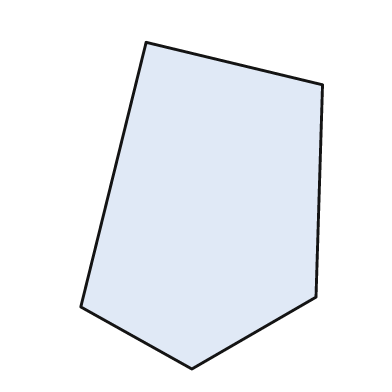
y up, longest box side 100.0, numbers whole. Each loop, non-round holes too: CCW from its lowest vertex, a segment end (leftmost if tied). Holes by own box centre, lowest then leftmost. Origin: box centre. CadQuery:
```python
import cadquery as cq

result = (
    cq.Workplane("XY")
    .moveTo(-3.0, -50.0)
    .lineTo(35.0, -28.0)
    .lineTo(37.0, 37.0)
    .lineTo(-17.0, 50.0)
    .lineTo(-37.0, -31.0)
    .close()
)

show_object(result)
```